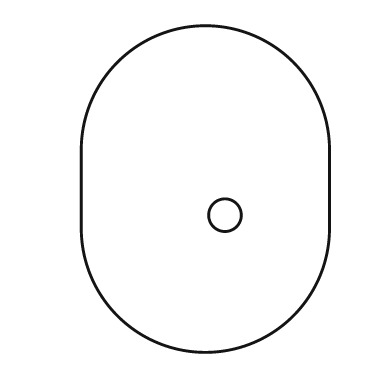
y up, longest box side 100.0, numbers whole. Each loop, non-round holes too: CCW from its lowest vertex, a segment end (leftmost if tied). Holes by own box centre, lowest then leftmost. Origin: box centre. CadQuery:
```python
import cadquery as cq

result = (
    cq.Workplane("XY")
    .moveTo(-38.0, -12.0)
    .threePointArc((0.0, -50.0), (38.0, -12.0))
    .lineTo(38.0, 12.0)
    .threePointArc((0.0, 50.0), (-38.0, 12.0))
    .close()
    .moveTo(6.0, -8.0)
    .circle(5.0)
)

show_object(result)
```